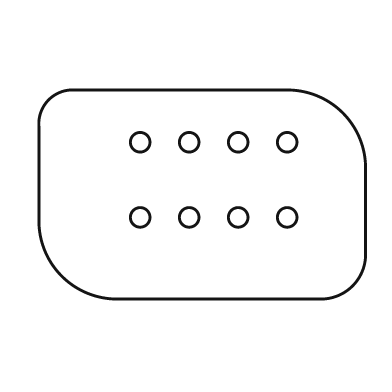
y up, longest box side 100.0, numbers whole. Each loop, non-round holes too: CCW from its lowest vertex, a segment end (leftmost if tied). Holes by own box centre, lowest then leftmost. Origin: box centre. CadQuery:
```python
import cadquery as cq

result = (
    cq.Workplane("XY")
    .moveTo(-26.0, -32.0)
    .lineTo(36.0, -32.0)
    .threePointArc((46.0, -28.0), (50.0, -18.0))
    .lineTo(50.0, 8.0)
    .threePointArc((43.0, 25.0), (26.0, 32.0))
    .lineTo(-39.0, 32.0)
    .threePointArc((-47.0, 29.0), (-50.0, 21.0))
    .lineTo(-50.0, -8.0)
    .threePointArc((-43.0, -25.0), (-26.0, -32.0))
    .close()
    .moveTo(-19.0, -7.0)
    .circle(3.0)
    .moveTo(-4.0, -7.0)
    .circle(3.0)
    .moveTo(11.0, -7.0)
    .circle(3.0)
    .moveTo(26.0, -7.0)
    .circle(3.0)
    .moveTo(-19.0, 16.0)
    .circle(3.0)
    .moveTo(-4.0, 16.0)
    .circle(3.0)
    .moveTo(11.0, 16.0)
    .circle(3.0)
    .moveTo(26.0, 16.0)
    .circle(3.0)
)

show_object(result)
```